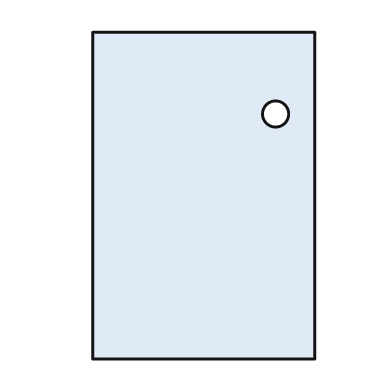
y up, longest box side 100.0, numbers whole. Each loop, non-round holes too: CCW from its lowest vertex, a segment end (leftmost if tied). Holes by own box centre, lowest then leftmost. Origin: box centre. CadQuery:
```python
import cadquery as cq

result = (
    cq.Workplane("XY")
    .moveTo(-34.0, -50.0)
    .lineTo(34.0, -50.0)
    .lineTo(34.0, 50.0)
    .lineTo(-34.0, 50.0)
    .close()
    .moveTo(22.0, 25.0)
    .circle(4.0)
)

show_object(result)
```